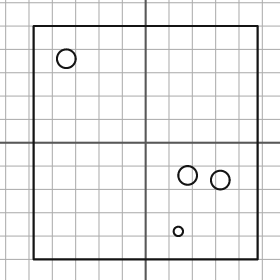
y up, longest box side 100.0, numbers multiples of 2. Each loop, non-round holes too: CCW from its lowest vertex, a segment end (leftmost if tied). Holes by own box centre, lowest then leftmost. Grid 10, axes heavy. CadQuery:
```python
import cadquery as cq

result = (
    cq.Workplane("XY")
    .moveTo(-48.0, -50.0)
    .lineTo(48.0, -50.0)
    .lineTo(48.0, 50.0)
    .lineTo(-48.0, 50.0)
    .close()
    .moveTo(14.0, -38.0)
    .circle(2.0)
    .moveTo(32.0, -16.0)
    .circle(4.0)
    .moveTo(18.0, -14.0)
    .circle(4.0)
    .moveTo(-34.0, 36.0)
    .circle(4.0)
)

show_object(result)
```